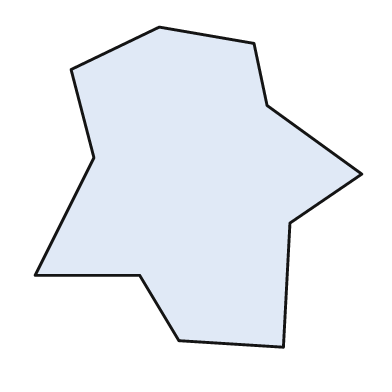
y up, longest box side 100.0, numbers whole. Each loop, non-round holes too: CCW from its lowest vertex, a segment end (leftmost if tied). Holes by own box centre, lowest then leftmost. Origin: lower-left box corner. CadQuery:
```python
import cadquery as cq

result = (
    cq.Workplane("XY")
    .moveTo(76.0, 0.0)
    .lineTo(78.0, 38.0)
    .lineTo(100.0, 53.0)
    .lineTo(71.0, 74.0)
    .lineTo(67.0, 93.0)
    .lineTo(38.0, 98.0)
    .lineTo(11.0, 85.0)
    .lineTo(18.0, 58.0)
    .lineTo(0.0, 22.0)
    .lineTo(32.0, 22.0)
    .lineTo(44.0, 2.0)
    .close()
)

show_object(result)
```